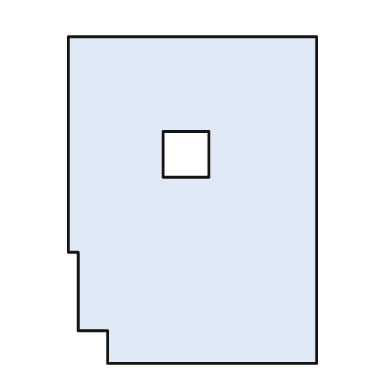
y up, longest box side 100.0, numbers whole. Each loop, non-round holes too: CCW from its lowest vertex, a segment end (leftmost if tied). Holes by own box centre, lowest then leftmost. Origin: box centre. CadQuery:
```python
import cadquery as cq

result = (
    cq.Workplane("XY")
    .moveTo(-26.0, -50.0)
    .lineTo(38.0, -50.0)
    .lineTo(38.0, 50.0)
    .lineTo(-38.0, 50.0)
    .lineTo(-38.0, -16.0)
    .lineTo(-35.0, -16.0)
    .lineTo(-35.0, -40.0)
    .lineTo(-26.0, -40.0)
    .close()
    .moveTo(-9.0, 7.0)
    .lineTo(5.0, 7.0)
    .lineTo(5.0, 21.0)
    .lineTo(-9.0, 21.0)
    .close()
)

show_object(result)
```